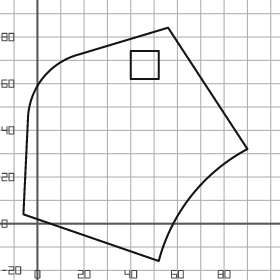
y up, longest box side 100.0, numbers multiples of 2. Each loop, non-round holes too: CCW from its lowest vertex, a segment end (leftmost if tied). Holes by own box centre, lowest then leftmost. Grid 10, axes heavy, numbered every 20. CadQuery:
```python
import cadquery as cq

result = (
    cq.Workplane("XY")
    .moveTo(52.0, -16.0)
    .threePointArc((66.0, 12.0), (90.0, 32.0))
    .lineTo(56.0, 84.0)
    .lineTo(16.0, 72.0)
    .threePointArc((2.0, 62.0), (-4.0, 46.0))
    .lineTo(-6.0, 4.0)
    .close()
    .moveTo(40.0, 62.0)
    .lineTo(52.0, 62.0)
    .lineTo(52.0, 74.0)
    .lineTo(40.0, 74.0)
    .close()
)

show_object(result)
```